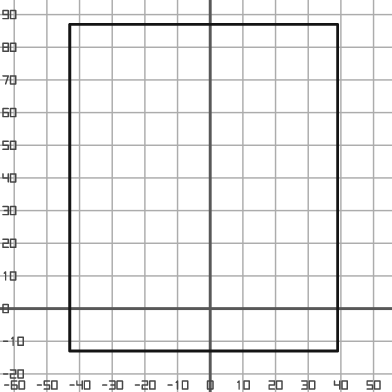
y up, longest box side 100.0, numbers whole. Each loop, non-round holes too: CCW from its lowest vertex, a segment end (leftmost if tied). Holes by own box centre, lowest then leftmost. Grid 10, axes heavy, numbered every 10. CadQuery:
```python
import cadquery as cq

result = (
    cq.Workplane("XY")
    .moveTo(-43.0, -13.0)
    .lineTo(39.0, -13.0)
    .lineTo(39.0, 87.0)
    .lineTo(-43.0, 87.0)
    .close()
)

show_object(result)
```